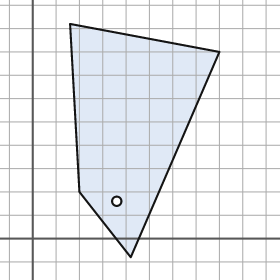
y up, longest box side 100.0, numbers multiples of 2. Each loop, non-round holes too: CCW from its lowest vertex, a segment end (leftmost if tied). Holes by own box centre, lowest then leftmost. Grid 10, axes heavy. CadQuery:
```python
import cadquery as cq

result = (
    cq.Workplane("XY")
    .moveTo(42.0, -8.0)
    .lineTo(80.0, 80.0)
    .lineTo(16.0, 92.0)
    .lineTo(20.0, 20.0)
    .close()
    .moveTo(36.0, 16.0)
    .circle(2.0)
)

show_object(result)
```